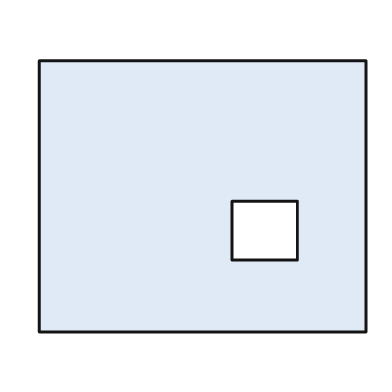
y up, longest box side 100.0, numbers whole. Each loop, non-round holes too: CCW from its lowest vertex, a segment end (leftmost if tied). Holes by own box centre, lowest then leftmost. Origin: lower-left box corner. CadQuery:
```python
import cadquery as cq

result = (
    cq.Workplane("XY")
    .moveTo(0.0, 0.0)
    .lineTo(100.0, 0.0)
    .lineTo(100.0, 83.0)
    .lineTo(0.0, 83.0)
    .close()
    .moveTo(59.0, 22.0)
    .lineTo(79.0, 22.0)
    .lineTo(79.0, 40.0)
    .lineTo(59.0, 40.0)
    .close()
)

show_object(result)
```